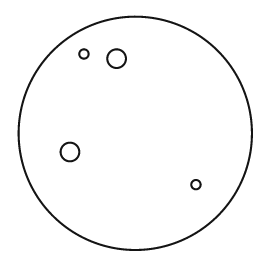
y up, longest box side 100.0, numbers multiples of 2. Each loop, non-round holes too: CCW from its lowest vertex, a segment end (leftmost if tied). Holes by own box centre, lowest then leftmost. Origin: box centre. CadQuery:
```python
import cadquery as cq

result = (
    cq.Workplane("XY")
    .moveTo(0.0, 0.0)
    .circle(50.0)
    .moveTo(26.0, -22.0)
    .circle(2.0)
    .moveTo(-28.0, -8.0)
    .circle(4.0)
    .moveTo(-8.0, 32.0)
    .circle(4.0)
    .moveTo(-22.0, 34.0)
    .circle(2.0)
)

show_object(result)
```